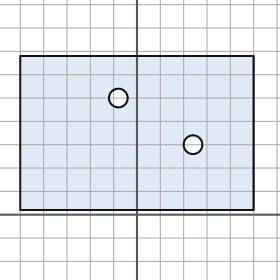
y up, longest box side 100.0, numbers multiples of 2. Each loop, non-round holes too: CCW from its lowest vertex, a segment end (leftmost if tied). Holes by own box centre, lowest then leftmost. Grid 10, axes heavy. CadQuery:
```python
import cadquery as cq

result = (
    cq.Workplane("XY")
    .moveTo(-50.0, 2.0)
    .lineTo(50.0, 2.0)
    .lineTo(50.0, 68.0)
    .lineTo(-50.0, 68.0)
    .close()
    .moveTo(24.0, 30.0)
    .circle(4.0)
    .moveTo(-8.0, 50.0)
    .circle(4.0)
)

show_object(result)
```